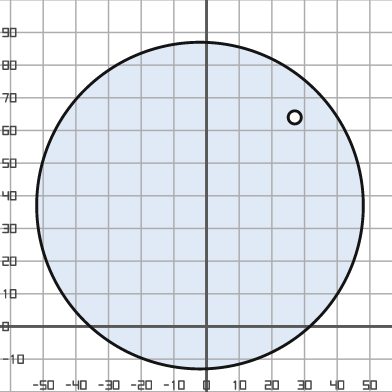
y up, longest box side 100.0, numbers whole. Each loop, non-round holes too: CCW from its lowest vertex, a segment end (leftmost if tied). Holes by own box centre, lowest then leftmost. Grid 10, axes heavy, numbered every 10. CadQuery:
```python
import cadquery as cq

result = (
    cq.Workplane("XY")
    .moveTo(-2.0, 37.0)
    .circle(50.0)
    .moveTo(27.0, 64.0)
    .circle(2.0)
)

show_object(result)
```